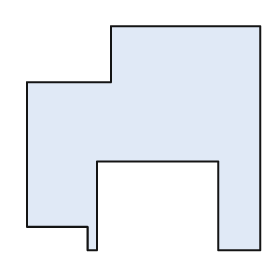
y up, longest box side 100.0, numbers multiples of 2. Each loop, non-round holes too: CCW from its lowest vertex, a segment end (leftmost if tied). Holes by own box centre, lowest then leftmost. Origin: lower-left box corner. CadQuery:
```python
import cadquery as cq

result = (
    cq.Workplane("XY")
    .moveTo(26.0, 0.0)
    .lineTo(30.0, 0.0)
    .lineTo(30.0, 38.0)
    .lineTo(82.0, 38.0)
    .lineTo(82.0, 0.0)
    .lineTo(100.0, 0.0)
    .lineTo(100.0, 96.0)
    .lineTo(36.0, 96.0)
    .lineTo(36.0, 72.0)
    .lineTo(0.0, 72.0)
    .lineTo(0.0, 10.0)
    .lineTo(26.0, 10.0)
    .close()
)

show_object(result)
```